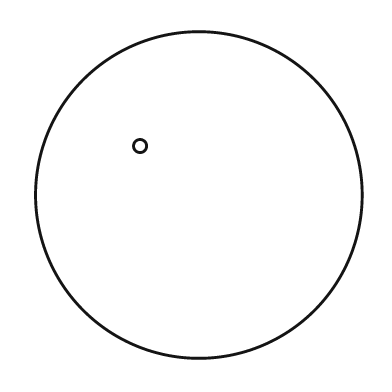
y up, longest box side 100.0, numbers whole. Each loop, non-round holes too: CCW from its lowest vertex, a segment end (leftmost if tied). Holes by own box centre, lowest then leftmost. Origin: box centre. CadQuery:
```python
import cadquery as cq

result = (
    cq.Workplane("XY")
    .moveTo(0.0, 0.0)
    .circle(50.0)
    .moveTo(-18.0, 15.0)
    .circle(2.0)
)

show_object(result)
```